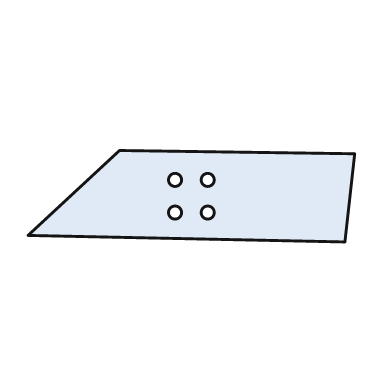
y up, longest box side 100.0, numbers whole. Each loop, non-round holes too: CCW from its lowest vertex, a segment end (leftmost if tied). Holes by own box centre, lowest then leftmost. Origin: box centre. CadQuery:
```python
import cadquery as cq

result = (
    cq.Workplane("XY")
    .moveTo(47.0, -14.0)
    .lineTo(50.0, 13.0)
    .lineTo(-22.0, 14.0)
    .lineTo(-50.0, -12.0)
    .close()
    .moveTo(-5.0, -5.0)
    .circle(2.0)
    .moveTo(5.0, -5.0)
    .circle(2.0)
    .moveTo(-5.0, 5.0)
    .circle(2.0)
    .moveTo(5.0, 5.0)
    .circle(2.0)
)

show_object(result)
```